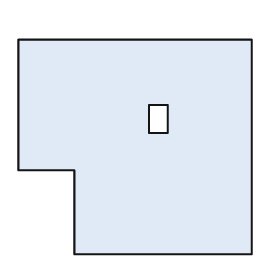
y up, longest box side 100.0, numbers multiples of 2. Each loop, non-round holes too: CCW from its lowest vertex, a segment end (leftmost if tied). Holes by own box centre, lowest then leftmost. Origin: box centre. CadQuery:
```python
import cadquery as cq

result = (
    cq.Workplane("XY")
    .moveTo(-26.0, -46.0)
    .lineTo(50.0, -46.0)
    .lineTo(50.0, 46.0)
    .lineTo(-50.0, 46.0)
    .lineTo(-50.0, -10.0)
    .lineTo(-26.0, -10.0)
    .close()
    .moveTo(6.0, 6.0)
    .lineTo(14.0, 6.0)
    .lineTo(14.0, 18.0)
    .lineTo(6.0, 18.0)
    .close()
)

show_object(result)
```